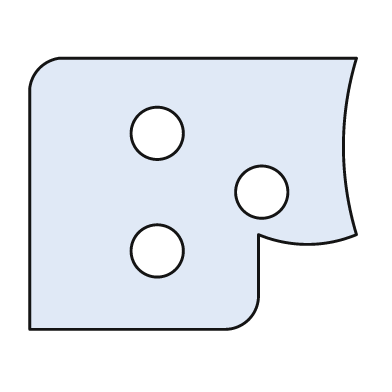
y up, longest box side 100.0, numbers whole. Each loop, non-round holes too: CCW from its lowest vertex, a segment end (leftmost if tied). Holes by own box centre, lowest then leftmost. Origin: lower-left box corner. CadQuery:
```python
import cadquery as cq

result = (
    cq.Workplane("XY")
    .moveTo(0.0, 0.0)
    .lineTo(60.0, 0.0)
    .threePointArc((67.0, 3.0), (70.0, 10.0))
    .lineTo(70.0, 29.0)
    .threePointArc((85.0, 26.0), (100.0, 29.0))
    .threePointArc((96.0, 56.0), (100.0, 83.0))
    .lineTo(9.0, 83.0)
    .threePointArc((3.0, 80.0), (0.0, 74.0))
    .close()
    .moveTo(39.0, 24.0)
    .circle(8.0)
    .moveTo(71.0, 42.0)
    .circle(8.0)
    .moveTo(39.0, 60.0)
    .circle(8.0)
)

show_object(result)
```